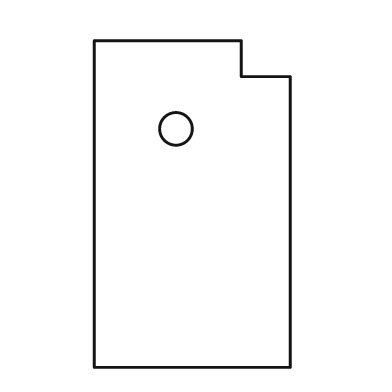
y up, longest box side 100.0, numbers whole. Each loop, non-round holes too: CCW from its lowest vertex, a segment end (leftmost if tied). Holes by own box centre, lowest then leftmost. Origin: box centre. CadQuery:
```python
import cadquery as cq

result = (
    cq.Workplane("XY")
    .moveTo(-30.0, -50.0)
    .lineTo(30.0, -50.0)
    .lineTo(30.0, 39.0)
    .lineTo(15.0, 39.0)
    .lineTo(15.0, 50.0)
    .lineTo(-30.0, 50.0)
    .close()
    .moveTo(-5.0, 23.0)
    .circle(5.0)
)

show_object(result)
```